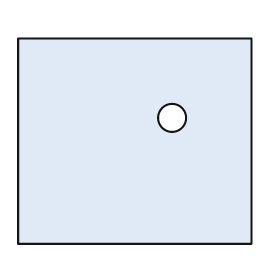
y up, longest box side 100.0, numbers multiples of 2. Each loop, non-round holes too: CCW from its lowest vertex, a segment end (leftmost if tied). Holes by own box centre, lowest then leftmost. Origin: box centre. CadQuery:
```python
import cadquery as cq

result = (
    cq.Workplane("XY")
    .moveTo(-50.0, -44.0)
    .lineTo(50.0, -44.0)
    .lineTo(50.0, 44.0)
    .lineTo(-50.0, 44.0)
    .close()
    .moveTo(16.0, 10.0)
    .circle(6.0)
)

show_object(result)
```